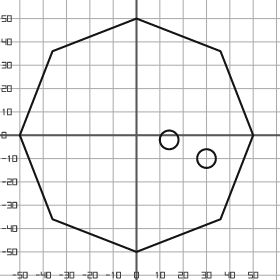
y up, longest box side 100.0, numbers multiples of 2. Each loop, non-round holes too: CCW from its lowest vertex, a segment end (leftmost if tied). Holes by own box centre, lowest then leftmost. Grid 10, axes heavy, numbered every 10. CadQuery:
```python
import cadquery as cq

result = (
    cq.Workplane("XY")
    .moveTo(0.0, -50.0)
    .lineTo(36.0, -36.0)
    .lineTo(50.0, 0.0)
    .lineTo(36.0, 36.0)
    .lineTo(0.0, 50.0)
    .lineTo(-36.0, 36.0)
    .lineTo(-50.0, 0.0)
    .lineTo(-36.0, -36.0)
    .close()
    .moveTo(30.0, -10.0)
    .circle(4.0)
    .moveTo(14.0, -2.0)
    .circle(4.0)
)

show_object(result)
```